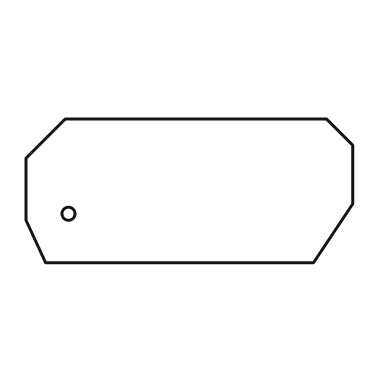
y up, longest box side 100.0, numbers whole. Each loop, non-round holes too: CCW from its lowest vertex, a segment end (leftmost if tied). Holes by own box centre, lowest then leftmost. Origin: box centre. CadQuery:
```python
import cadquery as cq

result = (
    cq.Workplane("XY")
    .moveTo(-44.0, -22.0)
    .lineTo(38.0, -22.0)
    .lineTo(50.0, -4.0)
    .lineTo(50.0, 14.0)
    .lineTo(42.0, 22.0)
    .lineTo(-38.0, 22.0)
    .lineTo(-50.0, 10.0)
    .lineTo(-50.0, -9.0)
    .close()
    .moveTo(-37.0, -7.0)
    .circle(2.0)
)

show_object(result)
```